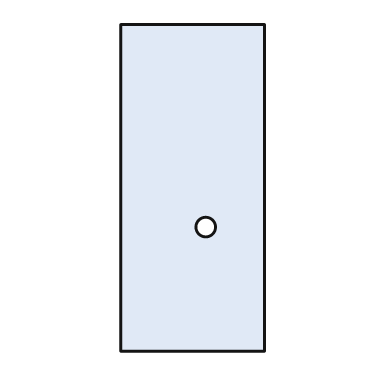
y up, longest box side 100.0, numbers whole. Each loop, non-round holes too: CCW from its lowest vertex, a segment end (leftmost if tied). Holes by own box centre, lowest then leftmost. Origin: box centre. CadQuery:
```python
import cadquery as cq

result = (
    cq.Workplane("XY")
    .moveTo(-22.0, -50.0)
    .lineTo(22.0, -50.0)
    .lineTo(22.0, 50.0)
    .lineTo(-22.0, 50.0)
    .close()
    .moveTo(4.0, -12.0)
    .circle(3.0)
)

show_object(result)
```